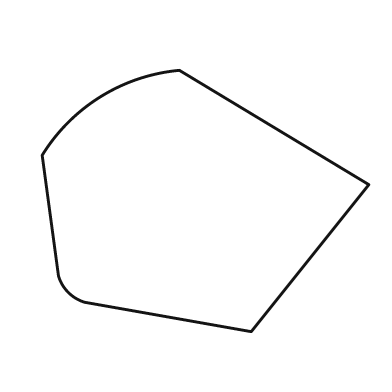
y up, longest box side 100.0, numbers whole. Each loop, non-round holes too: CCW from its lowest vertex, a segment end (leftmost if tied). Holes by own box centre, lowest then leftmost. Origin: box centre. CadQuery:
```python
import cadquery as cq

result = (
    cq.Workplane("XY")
    .moveTo(14.0, -40.0)
    .lineTo(50.0, 5.0)
    .lineTo(-8.0, 40.0)
    .threePointArc((-32.0, 32.0), (-50.0, 14.0))
    .lineTo(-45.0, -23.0)
    .threePointArc((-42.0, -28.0), (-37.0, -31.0))
    .close()
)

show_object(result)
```